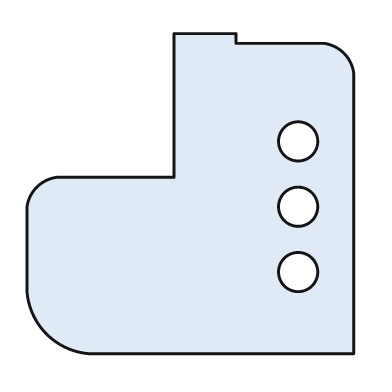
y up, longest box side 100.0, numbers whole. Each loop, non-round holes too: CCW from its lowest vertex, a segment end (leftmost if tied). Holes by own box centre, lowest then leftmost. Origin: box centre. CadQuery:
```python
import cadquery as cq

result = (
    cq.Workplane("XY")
    .moveTo(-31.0, -49.0)
    .lineTo(50.0, -49.0)
    .lineTo(50.0, 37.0)
    .threePointArc((47.0, 43.0), (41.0, 46.0))
    .lineTo(14.0, 46.0)
    .lineTo(14.0, 49.0)
    .lineTo(-5.0, 49.0)
    .lineTo(-5.0, 5.0)
    .lineTo(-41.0, 5.0)
    .threePointArc((-47.0, 2.0), (-50.0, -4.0))
    .lineTo(-50.0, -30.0)
    .threePointArc((-44.0, -43.0), (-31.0, -49.0))
    .close()
    .moveTo(33.0, -24.0)
    .circle(6.0)
    .moveTo(33.0, -4.0)
    .circle(6.0)
    .moveTo(33.0, 16.0)
    .circle(6.0)
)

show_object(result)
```